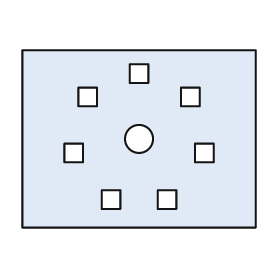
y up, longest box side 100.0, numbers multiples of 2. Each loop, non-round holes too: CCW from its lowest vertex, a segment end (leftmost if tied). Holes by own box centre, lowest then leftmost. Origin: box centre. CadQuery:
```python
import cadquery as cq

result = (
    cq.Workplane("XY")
    .moveTo(-50.0, -38.0)
    .lineTo(50.0, -38.0)
    .lineTo(50.0, 38.0)
    .lineTo(-50.0, 38.0)
    .close()
    .moveTo(-16.0, -30.0)
    .lineTo(-8.0, -30.0)
    .lineTo(-8.0, -22.0)
    .lineTo(-16.0, -22.0)
    .close()
    .moveTo(8.0, -30.0)
    .lineTo(16.0, -30.0)
    .lineTo(16.0, -22.0)
    .lineTo(8.0, -22.0)
    .close()
    .moveTo(-32.0, -10.0)
    .lineTo(-24.0, -10.0)
    .lineTo(-24.0, -2.0)
    .lineTo(-32.0, -2.0)
    .close()
    .moveTo(24.0, -10.0)
    .lineTo(32.0, -10.0)
    .lineTo(32.0, -2.0)
    .lineTo(24.0, -2.0)
    .close()
    .moveTo(0.0, 0.0)
    .circle(6.0)
    .moveTo(-26.0, 14.0)
    .lineTo(-18.0, 14.0)
    .lineTo(-18.0, 22.0)
    .lineTo(-26.0, 22.0)
    .close()
    .moveTo(18.0, 14.0)
    .lineTo(26.0, 14.0)
    .lineTo(26.0, 22.0)
    .lineTo(18.0, 22.0)
    .close()
    .moveTo(-4.0, 24.0)
    .lineTo(4.0, 24.0)
    .lineTo(4.0, 32.0)
    .lineTo(-4.0, 32.0)
    .close()
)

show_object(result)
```